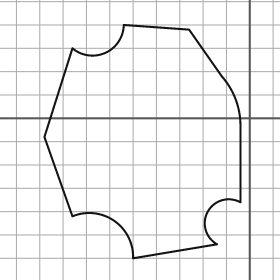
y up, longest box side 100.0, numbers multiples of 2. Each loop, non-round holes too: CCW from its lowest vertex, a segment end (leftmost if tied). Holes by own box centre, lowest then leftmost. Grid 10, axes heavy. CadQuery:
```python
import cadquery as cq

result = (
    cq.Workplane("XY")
    .moveTo(-50.0, -60.0)
    .lineTo(-14.0, -54.0)
    .threePointArc((-18.0, -40.0), (-4.0, -36.0))
    .lineTo(-4.0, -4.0)
    .threePointArc((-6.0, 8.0), (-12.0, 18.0))
    .lineTo(-26.0, 38.0)
    .lineTo(-54.0, 40.0)
    .threePointArc((-62.0, 28.0), (-76.0, 30.0))
    .lineTo(-88.0, -8.0)
    .lineTo(-76.0, -42.0)
    .threePointArc((-58.0, -44.0), (-50.0, -60.0))
    .close()
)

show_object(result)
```